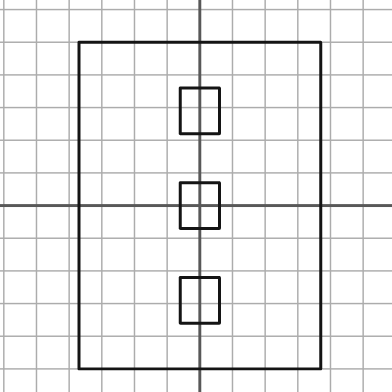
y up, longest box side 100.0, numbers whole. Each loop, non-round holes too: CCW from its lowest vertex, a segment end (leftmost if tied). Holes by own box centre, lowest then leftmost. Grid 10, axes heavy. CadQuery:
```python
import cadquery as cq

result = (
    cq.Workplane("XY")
    .moveTo(-37.0, -50.0)
    .lineTo(37.0, -50.0)
    .lineTo(37.0, 50.0)
    .lineTo(-37.0, 50.0)
    .close()
    .moveTo(-6.0, -36.0)
    .lineTo(6.0, -36.0)
    .lineTo(6.0, -22.0)
    .lineTo(-6.0, -22.0)
    .close()
    .moveTo(-6.0, -7.0)
    .lineTo(6.0, -7.0)
    .lineTo(6.0, 7.0)
    .lineTo(-6.0, 7.0)
    .close()
    .moveTo(-6.0, 22.0)
    .lineTo(6.0, 22.0)
    .lineTo(6.0, 36.0)
    .lineTo(-6.0, 36.0)
    .close()
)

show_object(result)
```